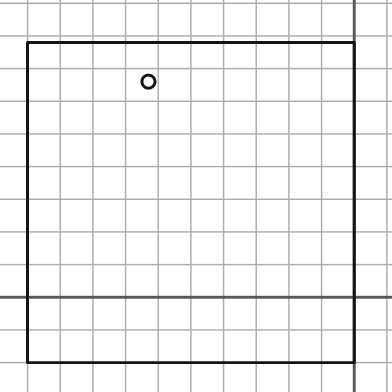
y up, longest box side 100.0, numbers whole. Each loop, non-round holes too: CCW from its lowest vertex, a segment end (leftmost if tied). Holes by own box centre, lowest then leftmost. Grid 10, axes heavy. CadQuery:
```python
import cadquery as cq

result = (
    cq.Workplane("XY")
    .moveTo(-100.0, -20.0)
    .lineTo(0.0, -20.0)
    .lineTo(0.0, 78.0)
    .lineTo(-100.0, 78.0)
    .close()
    .moveTo(-63.0, 66.0)
    .circle(2.0)
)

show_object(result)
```